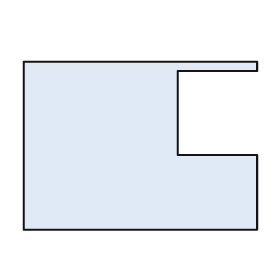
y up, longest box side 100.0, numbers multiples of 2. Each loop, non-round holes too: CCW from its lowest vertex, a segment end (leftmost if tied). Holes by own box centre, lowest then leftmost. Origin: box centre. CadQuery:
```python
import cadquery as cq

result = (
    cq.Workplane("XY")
    .moveTo(-50.0, -36.0)
    .lineTo(50.0, -36.0)
    .lineTo(50.0, -4.0)
    .lineTo(16.0, -4.0)
    .lineTo(16.0, 32.0)
    .lineTo(50.0, 32.0)
    .lineTo(50.0, 36.0)
    .lineTo(-50.0, 36.0)
    .close()
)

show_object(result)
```